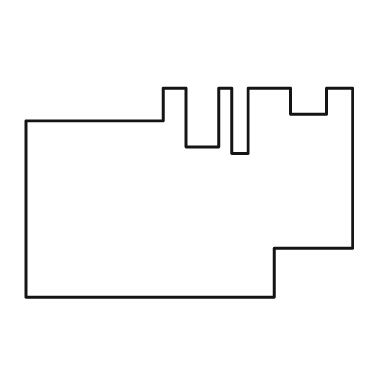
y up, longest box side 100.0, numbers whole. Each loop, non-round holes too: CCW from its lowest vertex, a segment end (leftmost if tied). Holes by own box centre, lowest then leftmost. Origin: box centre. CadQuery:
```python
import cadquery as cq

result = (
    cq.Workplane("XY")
    .moveTo(-50.0, -32.0)
    .lineTo(26.0, -32.0)
    .lineTo(26.0, -17.0)
    .lineTo(50.0, -17.0)
    .lineTo(50.0, 32.0)
    .lineTo(42.0, 32.0)
    .lineTo(42.0, 24.0)
    .lineTo(31.0, 24.0)
    .lineTo(31.0, 32.0)
    .lineTo(18.0, 32.0)
    .lineTo(18.0, 12.0)
    .lineTo(13.0, 12.0)
    .lineTo(13.0, 32.0)
    .lineTo(9.0, 32.0)
    .lineTo(9.0, 14.0)
    .lineTo(-1.0, 14.0)
    .lineTo(-1.0, 32.0)
    .lineTo(-8.0, 32.0)
    .lineTo(-8.0, 22.0)
    .lineTo(-50.0, 22.0)
    .close()
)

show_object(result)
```